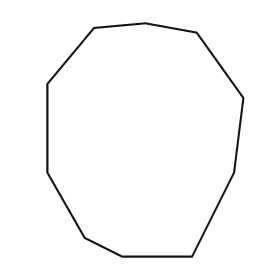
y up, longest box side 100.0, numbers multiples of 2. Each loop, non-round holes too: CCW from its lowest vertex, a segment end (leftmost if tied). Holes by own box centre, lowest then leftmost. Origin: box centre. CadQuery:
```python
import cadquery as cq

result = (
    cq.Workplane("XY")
    .moveTo(-10.0, -50.0)
    .lineTo(20.0, -50.0)
    .lineTo(38.0, -14.0)
    .lineTo(42.0, 18.0)
    .lineTo(22.0, 46.0)
    .lineTo(0.0, 50.0)
    .lineTo(-22.0, 48.0)
    .lineTo(-42.0, 24.0)
    .lineTo(-42.0, -14.0)
    .lineTo(-26.0, -42.0)
    .close()
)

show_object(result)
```